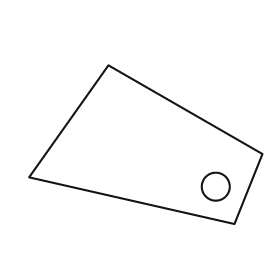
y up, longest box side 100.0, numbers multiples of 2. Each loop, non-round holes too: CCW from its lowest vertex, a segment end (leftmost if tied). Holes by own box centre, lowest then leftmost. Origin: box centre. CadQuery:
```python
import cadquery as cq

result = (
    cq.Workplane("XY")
    .moveTo(38.0, -34.0)
    .lineTo(50.0, -4.0)
    .lineTo(-16.0, 34.0)
    .lineTo(-50.0, -14.0)
    .close()
    .moveTo(30.0, -18.0)
    .circle(6.0)
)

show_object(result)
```